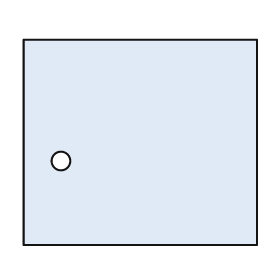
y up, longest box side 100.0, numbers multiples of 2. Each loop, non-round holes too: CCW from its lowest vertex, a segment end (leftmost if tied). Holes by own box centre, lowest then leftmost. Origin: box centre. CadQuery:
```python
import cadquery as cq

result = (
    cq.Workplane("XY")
    .moveTo(-50.0, -44.0)
    .lineTo(50.0, -44.0)
    .lineTo(50.0, 44.0)
    .lineTo(-50.0, 44.0)
    .close()
    .moveTo(-34.0, -8.0)
    .circle(4.0)
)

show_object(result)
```